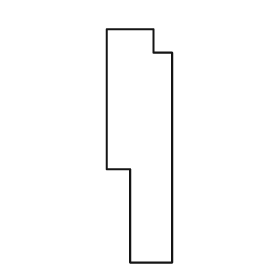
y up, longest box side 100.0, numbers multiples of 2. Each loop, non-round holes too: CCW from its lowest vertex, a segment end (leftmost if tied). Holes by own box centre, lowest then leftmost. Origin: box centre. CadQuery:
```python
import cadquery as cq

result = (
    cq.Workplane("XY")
    .moveTo(-4.0, -50.0)
    .lineTo(14.0, -50.0)
    .lineTo(14.0, 40.0)
    .lineTo(6.0, 40.0)
    .lineTo(6.0, 50.0)
    .lineTo(-14.0, 50.0)
    .lineTo(-14.0, -10.0)
    .lineTo(-4.0, -10.0)
    .close()
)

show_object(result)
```